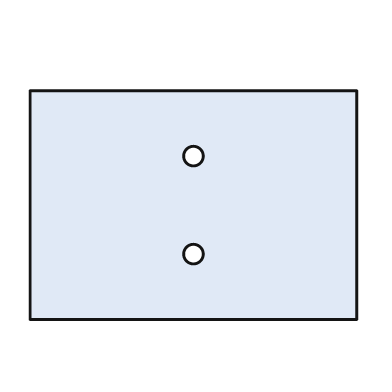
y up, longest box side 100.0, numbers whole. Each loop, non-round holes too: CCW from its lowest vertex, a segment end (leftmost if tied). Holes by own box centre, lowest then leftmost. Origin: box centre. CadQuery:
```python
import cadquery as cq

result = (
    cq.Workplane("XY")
    .moveTo(-50.0, -35.0)
    .lineTo(50.0, -35.0)
    .lineTo(50.0, 35.0)
    .lineTo(-50.0, 35.0)
    .close()
    .moveTo(0.0, -15.0)
    .circle(3.0)
    .moveTo(0.0, 15.0)
    .circle(3.0)
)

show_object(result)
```